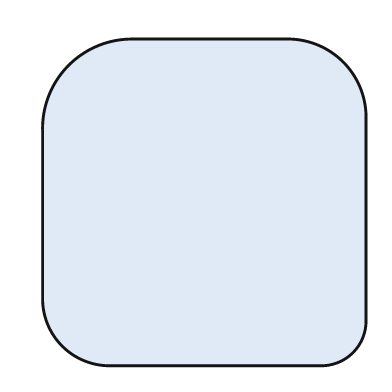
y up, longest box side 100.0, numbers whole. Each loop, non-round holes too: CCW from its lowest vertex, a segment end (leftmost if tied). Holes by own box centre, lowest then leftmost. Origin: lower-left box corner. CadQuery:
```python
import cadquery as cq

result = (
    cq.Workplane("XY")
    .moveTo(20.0, 0.0)
    .lineTo(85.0, 0.0)
    .threePointArc((95.0, 4.0), (99.0, 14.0))
    .lineTo(99.0, 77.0)
    .threePointArc((92.0, 93.0), (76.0, 100.0))
    .lineTo(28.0, 100.0)
    .threePointArc((8.0, 92.0), (0.0, 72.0))
    .lineTo(0.0, 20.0)
    .threePointArc((6.0, 6.0), (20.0, 0.0))
    .close()
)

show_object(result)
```